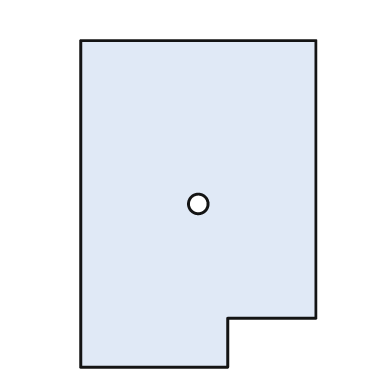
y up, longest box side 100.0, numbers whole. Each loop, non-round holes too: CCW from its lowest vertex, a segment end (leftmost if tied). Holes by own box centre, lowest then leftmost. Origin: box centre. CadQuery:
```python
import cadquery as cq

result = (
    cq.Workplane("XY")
    .moveTo(-36.0, -50.0)
    .lineTo(9.0, -50.0)
    .lineTo(9.0, -35.0)
    .lineTo(36.0, -35.0)
    .lineTo(36.0, 50.0)
    .lineTo(-36.0, 50.0)
    .close()
    .moveTo(0.0, 0.0)
    .circle(3.0)
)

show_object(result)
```